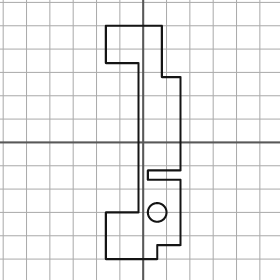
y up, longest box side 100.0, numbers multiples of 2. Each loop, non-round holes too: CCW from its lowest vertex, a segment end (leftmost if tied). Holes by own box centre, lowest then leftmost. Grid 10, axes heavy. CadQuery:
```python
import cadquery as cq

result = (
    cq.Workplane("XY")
    .moveTo(-16.0, -50.0)
    .lineTo(6.0, -50.0)
    .lineTo(6.0, -44.0)
    .lineTo(16.0, -44.0)
    .lineTo(16.0, -16.0)
    .lineTo(2.0, -16.0)
    .lineTo(2.0, -12.0)
    .lineTo(16.0, -12.0)
    .lineTo(16.0, 28.0)
    .lineTo(8.0, 28.0)
    .lineTo(8.0, 50.0)
    .lineTo(-16.0, 50.0)
    .lineTo(-16.0, 34.0)
    .lineTo(-2.0, 34.0)
    .lineTo(-2.0, -30.0)
    .lineTo(-16.0, -30.0)
    .close()
    .moveTo(6.0, -30.0)
    .circle(4.0)
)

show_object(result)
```